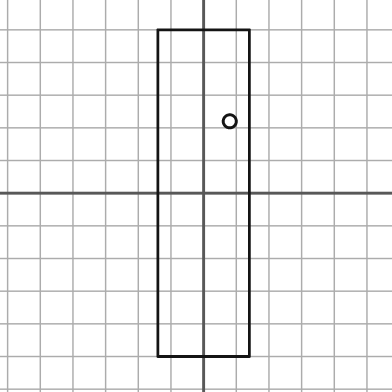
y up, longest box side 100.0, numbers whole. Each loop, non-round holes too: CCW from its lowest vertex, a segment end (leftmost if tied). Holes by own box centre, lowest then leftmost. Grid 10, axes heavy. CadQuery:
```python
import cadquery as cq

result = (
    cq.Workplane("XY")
    .moveTo(-14.0, -50.0)
    .lineTo(14.0, -50.0)
    .lineTo(14.0, 50.0)
    .lineTo(-14.0, 50.0)
    .close()
    .moveTo(8.0, 22.0)
    .circle(2.0)
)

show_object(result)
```